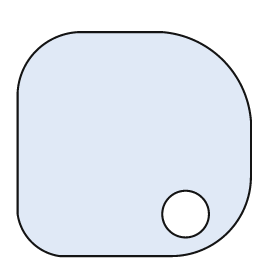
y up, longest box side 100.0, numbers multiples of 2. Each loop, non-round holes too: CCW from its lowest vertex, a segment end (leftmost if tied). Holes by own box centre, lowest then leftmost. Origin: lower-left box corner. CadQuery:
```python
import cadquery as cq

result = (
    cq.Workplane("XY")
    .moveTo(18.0, 0.0)
    .lineTo(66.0, 0.0)
    .threePointArc((90.0, 10.0), (100.0, 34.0))
    .lineTo(100.0, 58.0)
    .threePointArc((88.0, 84.0), (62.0, 96.0))
    .lineTo(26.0, 96.0)
    .threePointArc((8.0, 88.0), (0.0, 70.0))
    .lineTo(0.0, 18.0)
    .threePointArc((6.0, 6.0), (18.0, 0.0))
    .close()
    .moveTo(72.0, 18.0)
    .circle(10.0)
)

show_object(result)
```